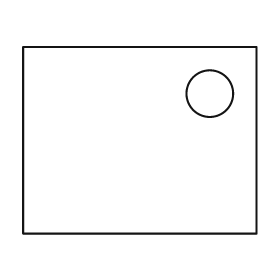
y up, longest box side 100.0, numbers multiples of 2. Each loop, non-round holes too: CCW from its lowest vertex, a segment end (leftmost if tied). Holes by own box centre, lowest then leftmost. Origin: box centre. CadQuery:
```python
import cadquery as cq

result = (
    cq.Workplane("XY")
    .moveTo(-50.0, -40.0)
    .lineTo(50.0, -40.0)
    .lineTo(50.0, 40.0)
    .lineTo(-50.0, 40.0)
    .close()
    .moveTo(30.0, 20.0)
    .circle(10.0)
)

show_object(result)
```